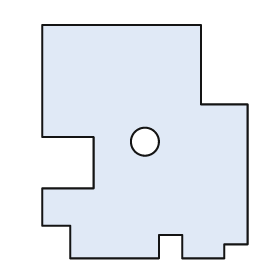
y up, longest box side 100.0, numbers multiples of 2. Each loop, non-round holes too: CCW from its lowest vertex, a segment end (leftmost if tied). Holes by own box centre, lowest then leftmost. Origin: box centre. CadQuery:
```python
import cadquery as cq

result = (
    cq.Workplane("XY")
    .moveTo(-32.0, -50.0)
    .lineTo(6.0, -50.0)
    .lineTo(6.0, -40.0)
    .lineTo(16.0, -40.0)
    .lineTo(16.0, -50.0)
    .lineTo(34.0, -50.0)
    .lineTo(34.0, -44.0)
    .lineTo(44.0, -44.0)
    .lineTo(44.0, 16.0)
    .lineTo(24.0, 16.0)
    .lineTo(24.0, 50.0)
    .lineTo(-44.0, 50.0)
    .lineTo(-44.0, 2.0)
    .lineTo(-22.0, 2.0)
    .lineTo(-22.0, -20.0)
    .lineTo(-44.0, -20.0)
    .lineTo(-44.0, -36.0)
    .lineTo(-32.0, -36.0)
    .close()
    .moveTo(0.0, 0.0)
    .circle(6.0)
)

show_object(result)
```